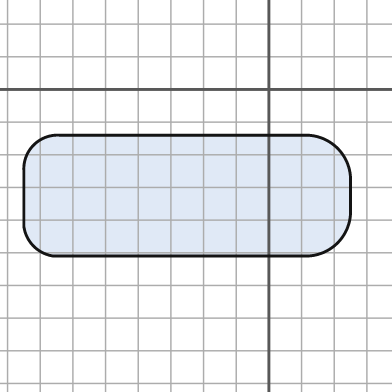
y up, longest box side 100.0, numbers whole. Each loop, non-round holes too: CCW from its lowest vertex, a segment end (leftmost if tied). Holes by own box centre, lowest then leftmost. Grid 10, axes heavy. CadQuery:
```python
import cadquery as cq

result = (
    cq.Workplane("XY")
    .moveTo(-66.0, -51.0)
    .lineTo(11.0, -51.0)
    .threePointArc((21.0, -47.0), (25.0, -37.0))
    .lineTo(25.0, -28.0)
    .threePointArc((21.0, -18.0), (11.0, -14.0))
    .lineTo(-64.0, -14.0)
    .threePointArc((-72.0, -17.0), (-75.0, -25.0))
    .lineTo(-75.0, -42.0)
    .threePointArc((-72.0, -48.0), (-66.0, -51.0))
    .close()
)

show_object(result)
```